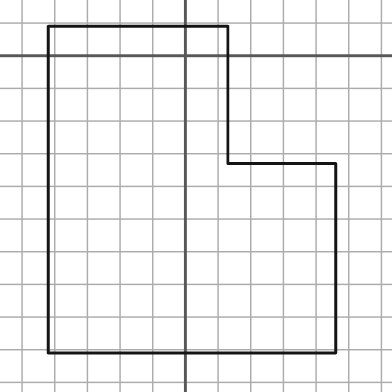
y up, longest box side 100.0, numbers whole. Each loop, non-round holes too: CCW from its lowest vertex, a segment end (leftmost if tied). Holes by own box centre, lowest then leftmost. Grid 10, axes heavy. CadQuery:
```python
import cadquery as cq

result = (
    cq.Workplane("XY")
    .moveTo(-42.0, -91.0)
    .lineTo(46.0, -91.0)
    .lineTo(46.0, -33.0)
    .lineTo(13.0, -33.0)
    .lineTo(13.0, 9.0)
    .lineTo(-42.0, 9.0)
    .close()
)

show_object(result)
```